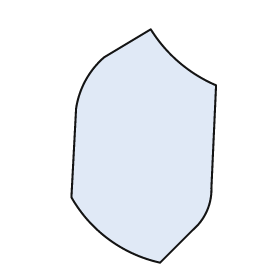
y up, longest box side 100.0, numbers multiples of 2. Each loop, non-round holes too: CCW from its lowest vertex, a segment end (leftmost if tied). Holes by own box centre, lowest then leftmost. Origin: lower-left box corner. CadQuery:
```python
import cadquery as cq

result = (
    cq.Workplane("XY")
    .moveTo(38.0, 0.0)
    .lineTo(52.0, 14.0)
    .threePointArc((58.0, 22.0), (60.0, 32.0))
    .lineTo(62.0, 76.0)
    .threePointArc((46.0, 86.0), (34.0, 100.0))
    .lineTo(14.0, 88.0)
    .threePointArc((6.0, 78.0), (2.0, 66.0))
    .lineTo(0.0, 28.0)
    .threePointArc((16.0, 10.0), (38.0, 0.0))
    .close()
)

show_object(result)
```